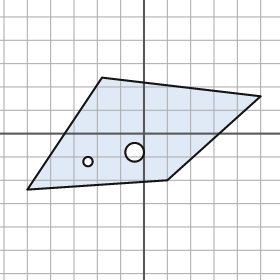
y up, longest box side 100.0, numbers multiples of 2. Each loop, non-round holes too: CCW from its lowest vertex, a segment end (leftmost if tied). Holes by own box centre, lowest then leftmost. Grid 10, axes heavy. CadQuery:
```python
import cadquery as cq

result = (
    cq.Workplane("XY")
    .moveTo(-50.0, -24.0)
    .lineTo(10.0, -20.0)
    .lineTo(50.0, 16.0)
    .lineTo(-18.0, 24.0)
    .close()
    .moveTo(-24.0, -12.0)
    .circle(2.0)
    .moveTo(-4.0, -8.0)
    .circle(4.0)
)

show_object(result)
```